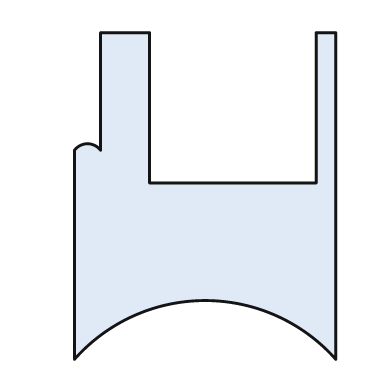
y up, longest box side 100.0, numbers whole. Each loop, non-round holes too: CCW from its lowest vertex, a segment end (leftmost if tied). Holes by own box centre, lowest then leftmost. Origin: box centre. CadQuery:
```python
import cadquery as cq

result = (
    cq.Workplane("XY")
    .moveTo(-40.0, -50.0)
    .threePointArc((0.0, -32.0), (40.0, -50.0))
    .lineTo(40.0, 50.0)
    .lineTo(34.0, 50.0)
    .lineTo(34.0, 4.0)
    .lineTo(-17.0, 4.0)
    .lineTo(-17.0, 50.0)
    .lineTo(-32.0, 50.0)
    .lineTo(-32.0, 14.0)
    .threePointArc((-36.0, 16.0), (-40.0, 14.0))
    .close()
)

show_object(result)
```